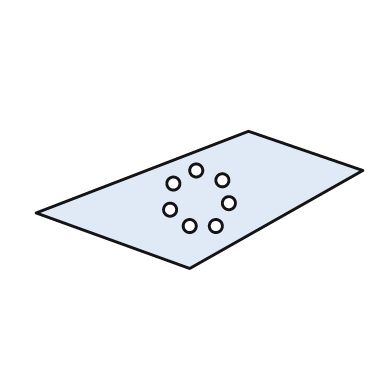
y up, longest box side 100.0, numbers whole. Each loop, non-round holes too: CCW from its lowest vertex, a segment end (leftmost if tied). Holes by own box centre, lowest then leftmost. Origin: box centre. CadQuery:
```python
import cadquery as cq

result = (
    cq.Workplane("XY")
    .moveTo(-3.0, -21.0)
    .lineTo(50.0, 9.0)
    .lineTo(15.0, 21.0)
    .lineTo(-50.0, -4.0)
    .close()
    .moveTo(-3.0, -8.0)
    .circle(2.0)
    .moveTo(5.0, -8.0)
    .circle(2.0)
    .moveTo(-9.0, -3.0)
    .circle(2.0)
    .moveTo(9.0, -1.0)
    .circle(2.0)
    .moveTo(-8.0, 5.0)
    .circle(2.0)
    .moveTo(7.0, 6.0)
    .circle(2.0)
    .moveTo(-1.0, 9.0)
    .circle(2.0)
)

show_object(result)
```